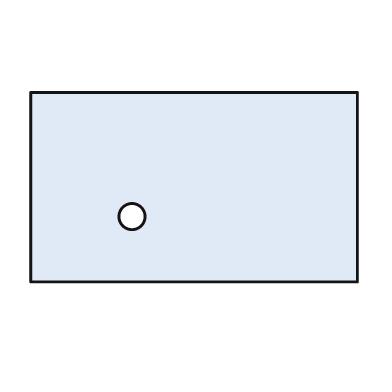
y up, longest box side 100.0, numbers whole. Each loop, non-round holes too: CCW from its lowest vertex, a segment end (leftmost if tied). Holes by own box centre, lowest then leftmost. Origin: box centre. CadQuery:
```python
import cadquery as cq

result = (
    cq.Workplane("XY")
    .moveTo(-50.0, -29.0)
    .lineTo(50.0, -29.0)
    .lineTo(50.0, 29.0)
    .lineTo(-50.0, 29.0)
    .close()
    .moveTo(-19.0, -9.0)
    .circle(4.0)
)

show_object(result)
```